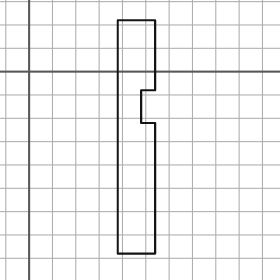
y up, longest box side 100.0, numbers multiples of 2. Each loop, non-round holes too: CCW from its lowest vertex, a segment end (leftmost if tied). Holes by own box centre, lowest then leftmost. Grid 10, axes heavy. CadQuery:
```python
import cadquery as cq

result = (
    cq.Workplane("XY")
    .moveTo(38.0, -78.0)
    .lineTo(54.0, -78.0)
    .lineTo(54.0, -22.0)
    .lineTo(48.0, -22.0)
    .lineTo(48.0, -8.0)
    .lineTo(54.0, -8.0)
    .lineTo(54.0, 22.0)
    .lineTo(38.0, 22.0)
    .close()
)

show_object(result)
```